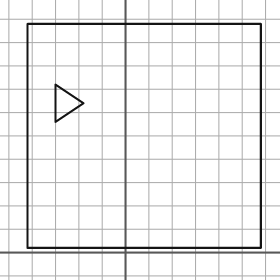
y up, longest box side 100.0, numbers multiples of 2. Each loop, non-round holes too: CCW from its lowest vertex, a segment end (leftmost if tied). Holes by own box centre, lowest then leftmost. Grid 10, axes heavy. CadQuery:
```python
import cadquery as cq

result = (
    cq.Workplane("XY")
    .moveTo(-42.0, 2.0)
    .lineTo(58.0, 2.0)
    .lineTo(58.0, 98.0)
    .lineTo(-42.0, 98.0)
    .close()
    .moveTo(-30.0, 56.0)
    .lineTo(-18.0, 64.0)
    .lineTo(-30.0, 72.0)
    .close()
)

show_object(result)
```